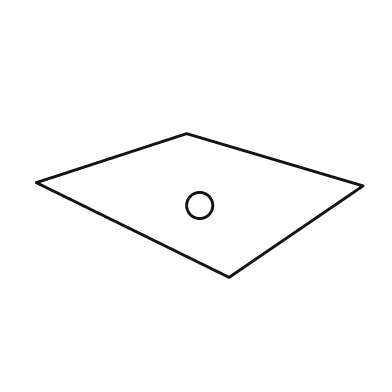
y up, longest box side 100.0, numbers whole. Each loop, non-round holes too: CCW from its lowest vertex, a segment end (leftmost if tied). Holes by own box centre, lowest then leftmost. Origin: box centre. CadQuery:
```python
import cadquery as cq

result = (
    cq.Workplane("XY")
    .moveTo(9.0, -22.0)
    .lineTo(50.0, 6.0)
    .lineTo(-4.0, 22.0)
    .lineTo(-50.0, 7.0)
    .close()
    .moveTo(0.0, 0.0)
    .circle(4.0)
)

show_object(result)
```